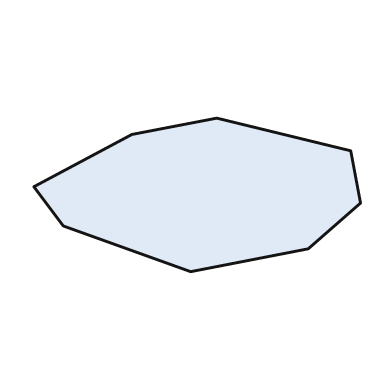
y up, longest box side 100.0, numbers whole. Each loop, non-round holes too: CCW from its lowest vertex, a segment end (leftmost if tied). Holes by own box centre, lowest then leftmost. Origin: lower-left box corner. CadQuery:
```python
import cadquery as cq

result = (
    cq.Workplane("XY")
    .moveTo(48.0, 0.0)
    .lineTo(84.0, 7.0)
    .lineTo(100.0, 21.0)
    .lineTo(97.0, 37.0)
    .lineTo(56.0, 47.0)
    .lineTo(30.0, 42.0)
    .lineTo(0.0, 26.0)
    .lineTo(9.0, 14.0)
    .close()
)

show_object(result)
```